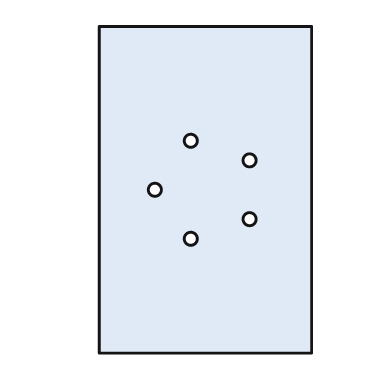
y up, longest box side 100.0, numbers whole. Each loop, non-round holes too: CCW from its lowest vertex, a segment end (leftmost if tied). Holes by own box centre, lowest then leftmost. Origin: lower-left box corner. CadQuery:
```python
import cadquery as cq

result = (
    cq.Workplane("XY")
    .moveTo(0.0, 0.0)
    .lineTo(65.0, 0.0)
    .lineTo(65.0, 100.0)
    .lineTo(0.0, 100.0)
    .close()
    .moveTo(28.0, 35.0)
    .circle(2.0)
    .moveTo(46.0, 41.0)
    .circle(2.0)
    .moveTo(17.0, 50.0)
    .circle(2.0)
    .moveTo(46.0, 59.0)
    .circle(2.0)
    .moveTo(28.0, 65.0)
    .circle(2.0)
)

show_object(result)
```